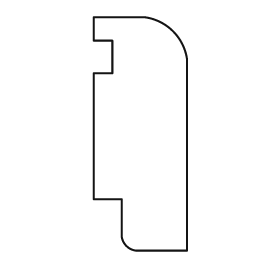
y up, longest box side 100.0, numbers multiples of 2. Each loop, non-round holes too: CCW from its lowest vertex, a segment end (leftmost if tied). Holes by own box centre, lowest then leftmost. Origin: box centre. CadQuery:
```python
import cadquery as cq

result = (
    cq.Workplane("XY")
    .moveTo(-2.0, -50.0)
    .lineTo(20.0, -50.0)
    .lineTo(20.0, 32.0)
    .threePointArc((14.0, 44.0), (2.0, 50.0))
    .lineTo(-20.0, 50.0)
    .lineTo(-20.0, 40.0)
    .lineTo(-12.0, 40.0)
    .lineTo(-12.0, 26.0)
    .lineTo(-20.0, 26.0)
    .lineTo(-20.0, -28.0)
    .lineTo(-8.0, -28.0)
    .lineTo(-8.0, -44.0)
    .threePointArc((-6.0, -48.0), (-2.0, -50.0))
    .close()
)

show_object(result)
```